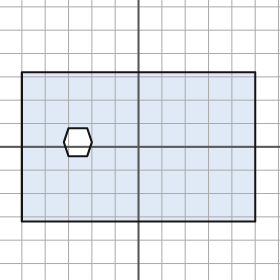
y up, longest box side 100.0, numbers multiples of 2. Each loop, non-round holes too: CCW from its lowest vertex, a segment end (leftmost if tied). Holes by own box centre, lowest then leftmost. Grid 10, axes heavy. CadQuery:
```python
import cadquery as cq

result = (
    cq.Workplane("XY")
    .moveTo(-50.0, -32.0)
    .lineTo(50.0, -32.0)
    .lineTo(50.0, 32.0)
    .lineTo(-50.0, 32.0)
    .close()
    .moveTo(-30.0, -4.0)
    .lineTo(-22.0, -4.0)
    .lineTo(-20.0, 2.0)
    .lineTo(-22.0, 8.0)
    .lineTo(-30.0, 8.0)
    .lineTo(-32.0, 2.0)
    .close()
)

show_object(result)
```